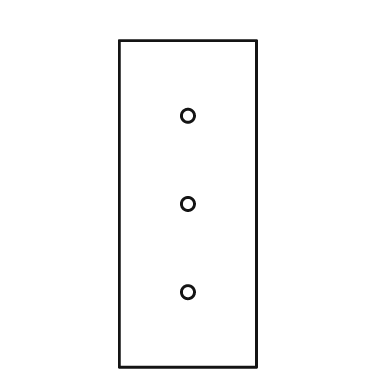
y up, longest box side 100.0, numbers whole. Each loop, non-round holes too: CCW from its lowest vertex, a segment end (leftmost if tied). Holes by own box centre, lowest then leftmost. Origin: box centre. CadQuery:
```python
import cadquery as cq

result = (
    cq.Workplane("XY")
    .moveTo(-21.0, -50.0)
    .lineTo(21.0, -50.0)
    .lineTo(21.0, 50.0)
    .lineTo(-21.0, 50.0)
    .close()
    .moveTo(0.0, -27.0)
    .circle(2.0)
    .moveTo(0.0, 0.0)
    .circle(2.0)
    .moveTo(0.0, 27.0)
    .circle(2.0)
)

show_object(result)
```